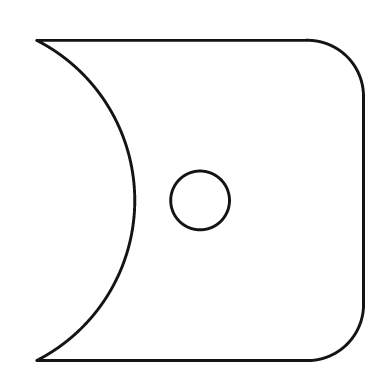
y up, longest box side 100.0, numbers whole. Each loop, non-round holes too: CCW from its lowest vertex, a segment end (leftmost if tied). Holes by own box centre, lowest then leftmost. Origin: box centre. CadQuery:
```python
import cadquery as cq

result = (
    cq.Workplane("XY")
    .moveTo(-50.0, -49.0)
    .lineTo(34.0, -49.0)
    .threePointArc((45.0, -44.0), (50.0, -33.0))
    .lineTo(50.0, 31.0)
    .threePointArc((45.0, 44.0), (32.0, 49.0))
    .lineTo(-50.0, 49.0)
    .threePointArc((-20.0, 0.0), (-50.0, -49.0))
    .close()
    .moveTo(0.0, 0.0)
    .circle(9.0)
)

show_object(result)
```